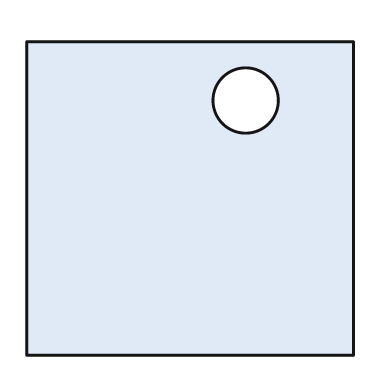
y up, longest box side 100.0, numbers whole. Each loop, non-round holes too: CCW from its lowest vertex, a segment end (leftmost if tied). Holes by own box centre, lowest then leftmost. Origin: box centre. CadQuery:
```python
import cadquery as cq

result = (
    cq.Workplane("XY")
    .moveTo(-50.0, -48.0)
    .lineTo(50.0, -48.0)
    .lineTo(50.0, 48.0)
    .lineTo(-50.0, 48.0)
    .close()
    .moveTo(17.0, 30.0)
    .circle(10.0)
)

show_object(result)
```